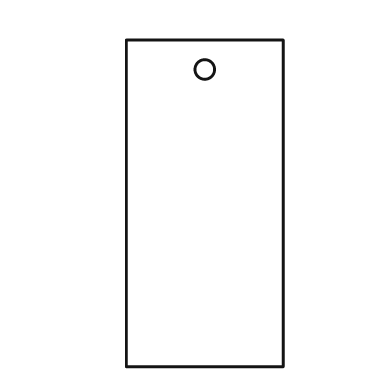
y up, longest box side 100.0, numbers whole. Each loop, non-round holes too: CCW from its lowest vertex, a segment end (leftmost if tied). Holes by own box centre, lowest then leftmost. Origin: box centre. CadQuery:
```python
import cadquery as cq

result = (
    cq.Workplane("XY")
    .moveTo(-24.0, -50.0)
    .lineTo(24.0, -50.0)
    .lineTo(24.0, 50.0)
    .lineTo(-24.0, 50.0)
    .close()
    .moveTo(0.0, 41.0)
    .circle(3.0)
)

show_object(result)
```